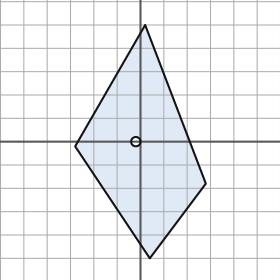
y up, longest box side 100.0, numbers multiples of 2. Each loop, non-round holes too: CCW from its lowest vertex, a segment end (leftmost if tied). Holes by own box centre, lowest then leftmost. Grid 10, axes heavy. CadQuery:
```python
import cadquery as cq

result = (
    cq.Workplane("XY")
    .moveTo(4.0, -50.0)
    .lineTo(28.0, -18.0)
    .lineTo(2.0, 50.0)
    .lineTo(-28.0, -2.0)
    .close()
    .moveTo(-2.0, 0.0)
    .circle(2.0)
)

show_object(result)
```